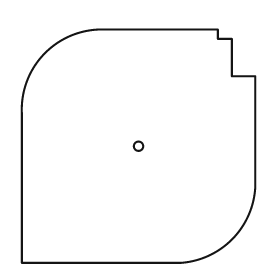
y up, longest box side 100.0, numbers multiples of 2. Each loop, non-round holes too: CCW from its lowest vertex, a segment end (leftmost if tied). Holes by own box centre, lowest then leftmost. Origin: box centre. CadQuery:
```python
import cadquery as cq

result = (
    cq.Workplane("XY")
    .moveTo(-50.0, -50.0)
    .lineTo(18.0, -50.0)
    .threePointArc((40.0, -40.0), (50.0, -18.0))
    .lineTo(50.0, 30.0)
    .lineTo(40.0, 30.0)
    .lineTo(40.0, 46.0)
    .lineTo(34.0, 46.0)
    .lineTo(34.0, 50.0)
    .lineTo(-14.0, 50.0)
    .threePointArc((-40.0, 40.0), (-50.0, 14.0))
    .close()
    .moveTo(0.0, 0.0)
    .circle(2.0)
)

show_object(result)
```